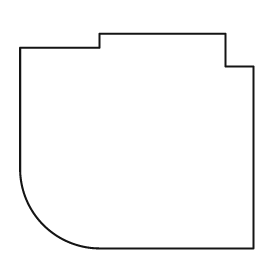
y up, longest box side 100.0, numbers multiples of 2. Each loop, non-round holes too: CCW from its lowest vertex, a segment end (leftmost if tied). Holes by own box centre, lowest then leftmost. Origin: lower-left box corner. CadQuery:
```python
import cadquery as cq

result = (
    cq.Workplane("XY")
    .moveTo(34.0, 0.0)
    .lineTo(100.0, 0.0)
    .lineTo(100.0, 78.0)
    .lineTo(88.0, 78.0)
    .lineTo(88.0, 92.0)
    .lineTo(34.0, 92.0)
    .lineTo(34.0, 86.0)
    .lineTo(0.0, 86.0)
    .lineTo(0.0, 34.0)
    .threePointArc((10.0, 10.0), (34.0, 0.0))
    .close()
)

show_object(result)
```